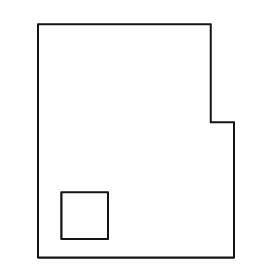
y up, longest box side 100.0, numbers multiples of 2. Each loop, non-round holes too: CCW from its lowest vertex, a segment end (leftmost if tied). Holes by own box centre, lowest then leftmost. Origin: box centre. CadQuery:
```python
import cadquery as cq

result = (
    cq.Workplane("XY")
    .moveTo(-42.0, -50.0)
    .lineTo(42.0, -50.0)
    .lineTo(42.0, 8.0)
    .lineTo(32.0, 8.0)
    .lineTo(32.0, 50.0)
    .lineTo(-42.0, 50.0)
    .close()
    .moveTo(-32.0, -42.0)
    .lineTo(-12.0, -42.0)
    .lineTo(-12.0, -22.0)
    .lineTo(-32.0, -22.0)
    .close()
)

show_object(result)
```